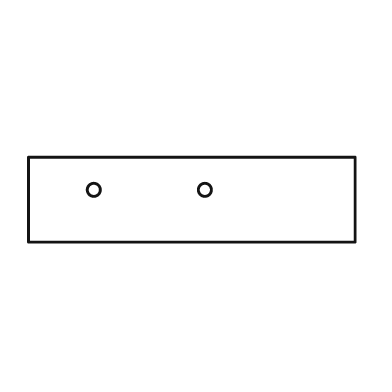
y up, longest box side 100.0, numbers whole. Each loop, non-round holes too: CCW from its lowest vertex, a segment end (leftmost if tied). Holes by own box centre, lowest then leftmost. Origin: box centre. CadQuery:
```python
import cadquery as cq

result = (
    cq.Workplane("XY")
    .moveTo(-50.0, -13.0)
    .lineTo(50.0, -13.0)
    .lineTo(50.0, 13.0)
    .lineTo(-50.0, 13.0)
    .close()
    .moveTo(-30.0, 3.0)
    .circle(2.0)
    .moveTo(4.0, 3.0)
    .circle(2.0)
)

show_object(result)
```